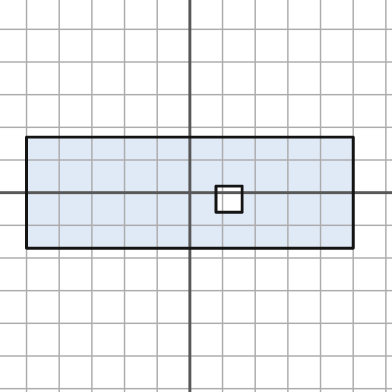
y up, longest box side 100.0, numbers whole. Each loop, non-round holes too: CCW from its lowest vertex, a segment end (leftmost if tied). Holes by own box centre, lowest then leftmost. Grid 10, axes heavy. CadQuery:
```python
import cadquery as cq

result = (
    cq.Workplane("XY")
    .moveTo(-50.0, -17.0)
    .lineTo(50.0, -17.0)
    .lineTo(50.0, 17.0)
    .lineTo(-50.0, 17.0)
    .close()
    .moveTo(8.0, -6.0)
    .lineTo(16.0, -6.0)
    .lineTo(16.0, 2.0)
    .lineTo(8.0, 2.0)
    .close()
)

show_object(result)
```